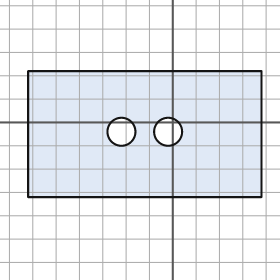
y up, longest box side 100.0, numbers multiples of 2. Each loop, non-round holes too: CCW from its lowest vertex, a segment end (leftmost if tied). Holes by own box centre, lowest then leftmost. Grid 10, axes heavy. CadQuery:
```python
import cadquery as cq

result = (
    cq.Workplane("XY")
    .moveTo(-62.0, -32.0)
    .lineTo(38.0, -32.0)
    .lineTo(38.0, 22.0)
    .lineTo(-62.0, 22.0)
    .close()
    .moveTo(-22.0, -4.0)
    .circle(6.0)
    .moveTo(-2.0, -4.0)
    .circle(6.0)
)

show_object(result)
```